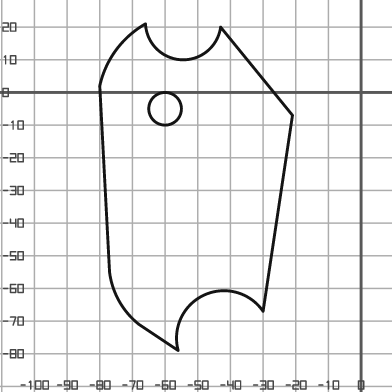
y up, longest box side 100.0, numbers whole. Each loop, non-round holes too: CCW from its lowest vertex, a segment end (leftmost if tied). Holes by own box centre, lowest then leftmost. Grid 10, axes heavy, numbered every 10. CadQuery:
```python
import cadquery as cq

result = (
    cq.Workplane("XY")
    .moveTo(-56.0, -79.0)
    .threePointArc((-48.0, -62.0), (-30.0, -67.0))
    .lineTo(-21.0, -7.0)
    .lineTo(-43.0, 20.0)
    .threePointArc((-55.0, 10.0), (-66.0, 21.0))
    .threePointArc((-75.0, 13.0), (-80.0, 2.0))
    .lineTo(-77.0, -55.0)
    .threePointArc((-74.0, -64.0), (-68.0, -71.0))
    .close()
    .moveTo(-60.0, -5.0)
    .circle(5.0)
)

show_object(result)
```